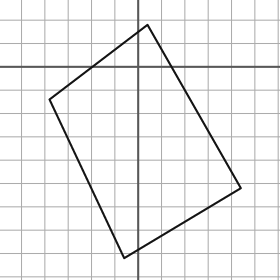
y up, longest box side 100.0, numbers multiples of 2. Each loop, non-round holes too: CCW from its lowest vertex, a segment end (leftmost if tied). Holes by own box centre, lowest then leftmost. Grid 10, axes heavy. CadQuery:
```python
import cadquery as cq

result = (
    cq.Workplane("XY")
    .moveTo(-6.0, -82.0)
    .lineTo(44.0, -52.0)
    .lineTo(4.0, 18.0)
    .lineTo(-38.0, -14.0)
    .close()
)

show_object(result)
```